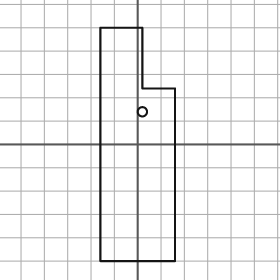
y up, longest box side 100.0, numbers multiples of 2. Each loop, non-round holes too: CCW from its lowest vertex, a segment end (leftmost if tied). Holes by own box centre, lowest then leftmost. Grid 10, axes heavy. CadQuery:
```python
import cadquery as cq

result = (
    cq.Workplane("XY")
    .moveTo(-16.0, -50.0)
    .lineTo(16.0, -50.0)
    .lineTo(16.0, 24.0)
    .lineTo(2.0, 24.0)
    .lineTo(2.0, 50.0)
    .lineTo(-16.0, 50.0)
    .close()
    .moveTo(2.0, 14.0)
    .circle(2.0)
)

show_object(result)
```